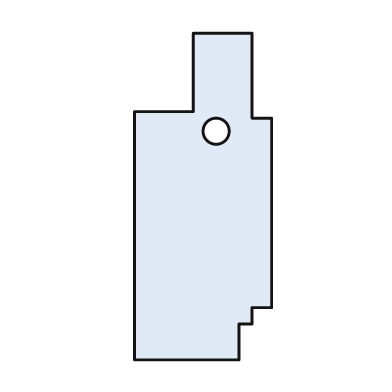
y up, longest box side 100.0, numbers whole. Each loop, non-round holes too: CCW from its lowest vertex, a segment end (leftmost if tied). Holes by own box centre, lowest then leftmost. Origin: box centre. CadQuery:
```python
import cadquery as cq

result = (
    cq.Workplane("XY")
    .moveTo(-21.0, -50.0)
    .lineTo(11.0, -50.0)
    .lineTo(11.0, -39.0)
    .lineTo(15.0, -39.0)
    .lineTo(15.0, -34.0)
    .lineTo(21.0, -34.0)
    .lineTo(21.0, 24.0)
    .lineTo(15.0, 24.0)
    .lineTo(15.0, 50.0)
    .lineTo(-3.0, 50.0)
    .lineTo(-3.0, 26.0)
    .lineTo(-21.0, 26.0)
    .close()
    .moveTo(4.0, 20.0)
    .circle(4.0)
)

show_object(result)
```